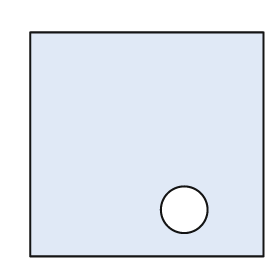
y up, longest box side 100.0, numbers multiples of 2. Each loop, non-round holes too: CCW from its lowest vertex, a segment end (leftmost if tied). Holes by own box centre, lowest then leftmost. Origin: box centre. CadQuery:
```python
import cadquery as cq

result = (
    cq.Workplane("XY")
    .moveTo(-50.0, -48.0)
    .lineTo(50.0, -48.0)
    .lineTo(50.0, 48.0)
    .lineTo(-50.0, 48.0)
    .close()
    .moveTo(16.0, -28.0)
    .circle(10.0)
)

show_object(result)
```